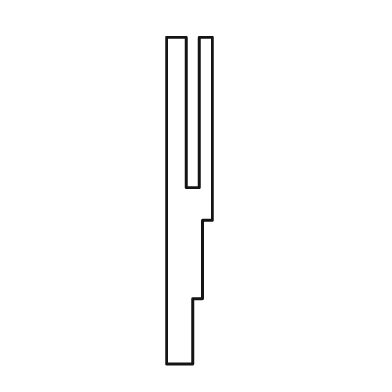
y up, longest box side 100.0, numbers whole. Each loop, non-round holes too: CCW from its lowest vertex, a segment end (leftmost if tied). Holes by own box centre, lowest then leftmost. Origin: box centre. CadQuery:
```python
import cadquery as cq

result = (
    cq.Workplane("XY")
    .moveTo(-7.0, -50.0)
    .lineTo(1.0, -50.0)
    .lineTo(1.0, -30.0)
    .lineTo(4.0, -30.0)
    .lineTo(4.0, -6.0)
    .lineTo(7.0, -6.0)
    .lineTo(7.0, 50.0)
    .lineTo(3.0, 50.0)
    .lineTo(3.0, 4.0)
    .lineTo(-1.0, 4.0)
    .lineTo(-1.0, 50.0)
    .lineTo(-7.0, 50.0)
    .close()
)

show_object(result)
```